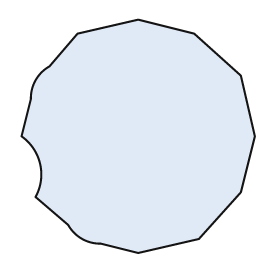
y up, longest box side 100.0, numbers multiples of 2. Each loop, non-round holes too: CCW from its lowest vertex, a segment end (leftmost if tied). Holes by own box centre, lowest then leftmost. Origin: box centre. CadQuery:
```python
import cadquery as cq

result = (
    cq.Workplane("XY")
    .moveTo(0.0, -50.0)
    .lineTo(26.0, -44.0)
    .lineTo(44.0, -24.0)
    .lineTo(50.0, 0.0)
    .lineTo(44.0, 26.0)
    .lineTo(24.0, 44.0)
    .lineTo(0.0, 50.0)
    .lineTo(-26.0, 44.0)
    .lineTo(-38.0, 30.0)
    .threePointArc((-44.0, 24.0), (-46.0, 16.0))
    .lineTo(-50.0, 0.0)
    .threePointArc((-42.0, -12.0), (-44.0, -26.0))
    .lineTo(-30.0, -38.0)
    .threePointArc((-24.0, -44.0), (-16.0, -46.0))
    .close()
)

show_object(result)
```